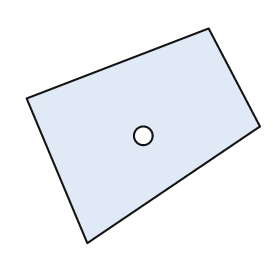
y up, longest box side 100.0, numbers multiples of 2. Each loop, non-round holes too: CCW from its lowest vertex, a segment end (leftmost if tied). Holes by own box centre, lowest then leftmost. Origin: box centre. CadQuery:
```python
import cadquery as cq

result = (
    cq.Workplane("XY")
    .moveTo(-24.0, -46.0)
    .lineTo(50.0, 4.0)
    .lineTo(28.0, 46.0)
    .lineTo(-50.0, 16.0)
    .close()
    .moveTo(0.0, 0.0)
    .circle(4.0)
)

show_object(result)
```